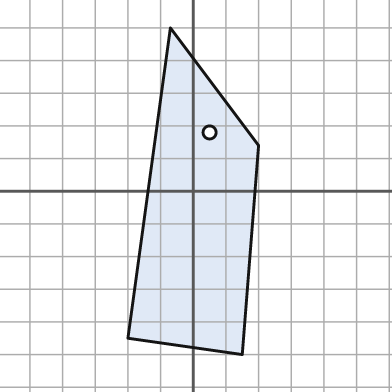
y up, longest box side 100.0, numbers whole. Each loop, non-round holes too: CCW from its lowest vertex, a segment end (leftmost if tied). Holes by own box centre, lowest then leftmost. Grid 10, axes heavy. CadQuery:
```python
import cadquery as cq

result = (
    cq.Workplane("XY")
    .moveTo(15.0, -50.0)
    .lineTo(20.0, 14.0)
    .lineTo(-7.0, 50.0)
    .lineTo(-20.0, -45.0)
    .close()
    .moveTo(5.0, 18.0)
    .circle(2.0)
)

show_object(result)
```